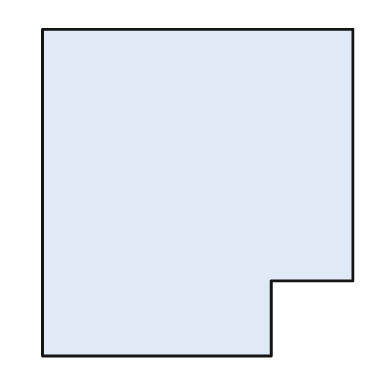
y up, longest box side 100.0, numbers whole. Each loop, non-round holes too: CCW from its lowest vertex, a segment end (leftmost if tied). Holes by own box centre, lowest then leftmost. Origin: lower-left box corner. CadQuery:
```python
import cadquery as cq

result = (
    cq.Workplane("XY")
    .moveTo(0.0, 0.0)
    .lineTo(70.0, 0.0)
    .lineTo(70.0, 23.0)
    .lineTo(95.0, 23.0)
    .lineTo(95.0, 100.0)
    .lineTo(0.0, 100.0)
    .close()
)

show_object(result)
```